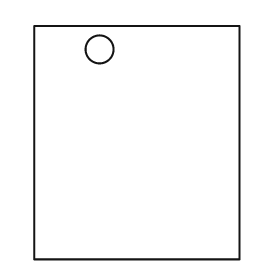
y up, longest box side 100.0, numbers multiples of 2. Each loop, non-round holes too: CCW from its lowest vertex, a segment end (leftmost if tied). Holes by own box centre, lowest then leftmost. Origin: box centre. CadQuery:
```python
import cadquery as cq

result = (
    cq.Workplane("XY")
    .moveTo(-44.0, -50.0)
    .lineTo(44.0, -50.0)
    .lineTo(44.0, 50.0)
    .lineTo(-44.0, 50.0)
    .close()
    .moveTo(-16.0, 40.0)
    .circle(6.0)
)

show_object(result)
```